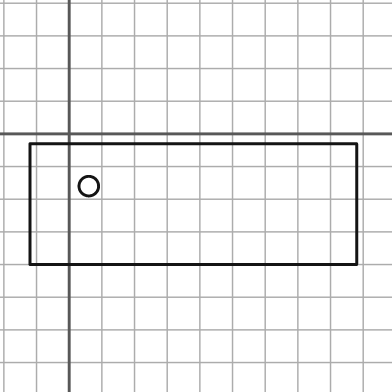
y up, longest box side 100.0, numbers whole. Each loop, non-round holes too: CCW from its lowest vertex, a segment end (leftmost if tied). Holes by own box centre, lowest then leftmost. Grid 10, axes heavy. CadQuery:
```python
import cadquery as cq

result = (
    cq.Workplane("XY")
    .moveTo(-12.0, -40.0)
    .lineTo(88.0, -40.0)
    .lineTo(88.0, -3.0)
    .lineTo(-12.0, -3.0)
    .close()
    .moveTo(6.0, -16.0)
    .circle(3.0)
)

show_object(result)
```